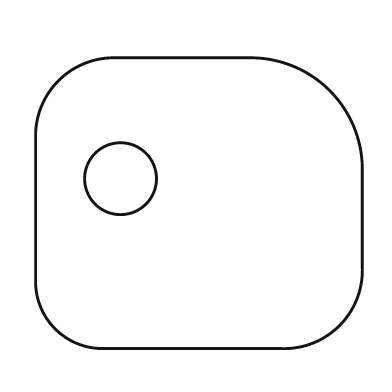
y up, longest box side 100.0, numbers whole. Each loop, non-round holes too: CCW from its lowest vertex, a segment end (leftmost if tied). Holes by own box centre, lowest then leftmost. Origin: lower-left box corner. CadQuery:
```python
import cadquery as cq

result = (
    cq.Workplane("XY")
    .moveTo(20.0, 0.0)
    .lineTo(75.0, 0.0)
    .threePointArc((93.0, 7.0), (100.0, 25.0))
    .lineTo(100.0, 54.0)
    .threePointArc((90.0, 79.0), (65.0, 89.0))
    .lineTo(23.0, 89.0)
    .threePointArc((7.0, 82.0), (0.0, 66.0))
    .lineTo(0.0, 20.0)
    .threePointArc((6.0, 6.0), (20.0, 0.0))
    .close()
    .moveTo(26.0, 52.0)
    .circle(11.0)
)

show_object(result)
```